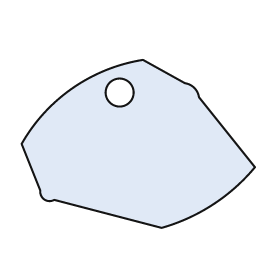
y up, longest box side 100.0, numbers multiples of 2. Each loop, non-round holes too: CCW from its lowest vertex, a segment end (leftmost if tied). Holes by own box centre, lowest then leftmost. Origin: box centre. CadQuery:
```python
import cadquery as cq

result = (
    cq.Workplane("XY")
    .moveTo(10.0, -36.0)
    .threePointArc((32.0, -26.0), (50.0, -10.0))
    .lineTo(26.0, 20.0)
    .threePointArc((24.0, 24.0), (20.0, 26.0))
    .lineTo(2.0, 36.0)
    .threePointArc((-28.0, 24.0), (-50.0, 0.0))
    .lineTo(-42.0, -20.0)
    .threePointArc((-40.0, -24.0), (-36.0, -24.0))
    .close()
    .moveTo(-8.0, 22.0)
    .circle(6.0)
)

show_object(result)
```